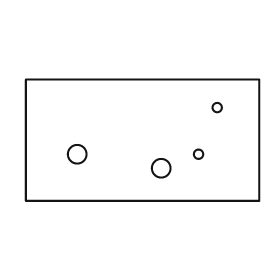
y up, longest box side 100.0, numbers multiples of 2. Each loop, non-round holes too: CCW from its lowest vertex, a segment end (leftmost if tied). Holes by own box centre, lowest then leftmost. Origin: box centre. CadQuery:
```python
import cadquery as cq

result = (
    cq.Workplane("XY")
    .moveTo(-50.0, -26.0)
    .lineTo(50.0, -26.0)
    .lineTo(50.0, 26.0)
    .lineTo(-50.0, 26.0)
    .close()
    .moveTo(8.0, -12.0)
    .circle(4.0)
    .moveTo(-28.0, -6.0)
    .circle(4.0)
    .moveTo(24.0, -6.0)
    .circle(2.0)
    .moveTo(32.0, 14.0)
    .circle(2.0)
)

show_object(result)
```